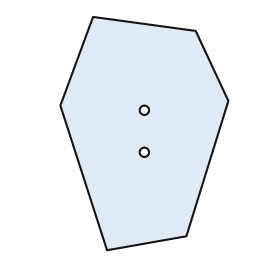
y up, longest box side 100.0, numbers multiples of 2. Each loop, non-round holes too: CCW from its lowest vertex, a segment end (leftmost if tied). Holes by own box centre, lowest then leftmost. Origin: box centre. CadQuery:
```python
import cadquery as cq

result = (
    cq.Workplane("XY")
    .moveTo(-16.0, -50.0)
    .lineTo(18.0, -44.0)
    .lineTo(36.0, 14.0)
    .lineTo(22.0, 44.0)
    .lineTo(-22.0, 50.0)
    .lineTo(-36.0, 12.0)
    .close()
    .moveTo(0.0, -8.0)
    .circle(2.0)
    .moveTo(0.0, 10.0)
    .circle(2.0)
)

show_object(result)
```